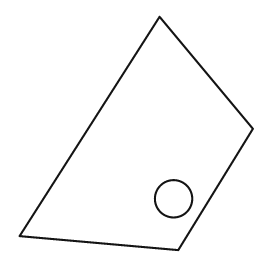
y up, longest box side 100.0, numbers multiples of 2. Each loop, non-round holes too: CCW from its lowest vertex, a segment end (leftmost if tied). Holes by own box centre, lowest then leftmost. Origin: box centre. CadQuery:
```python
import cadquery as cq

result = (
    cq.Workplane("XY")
    .moveTo(18.0, -50.0)
    .lineTo(50.0, 2.0)
    .lineTo(10.0, 50.0)
    .lineTo(-50.0, -44.0)
    .close()
    .moveTo(16.0, -28.0)
    .circle(8.0)
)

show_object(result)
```